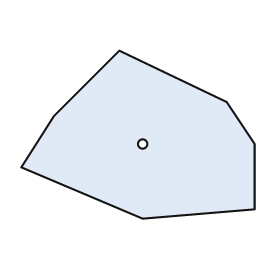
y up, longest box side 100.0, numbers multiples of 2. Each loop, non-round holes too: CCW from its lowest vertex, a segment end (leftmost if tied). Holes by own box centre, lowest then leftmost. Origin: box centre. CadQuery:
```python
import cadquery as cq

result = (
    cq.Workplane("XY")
    .moveTo(2.0, -36.0)
    .lineTo(50.0, -32.0)
    .lineTo(50.0, -4.0)
    .lineTo(38.0, 14.0)
    .lineTo(-8.0, 36.0)
    .lineTo(-36.0, 8.0)
    .lineTo(-50.0, -14.0)
    .close()
    .moveTo(2.0, -4.0)
    .circle(2.0)
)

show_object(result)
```